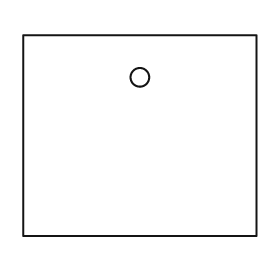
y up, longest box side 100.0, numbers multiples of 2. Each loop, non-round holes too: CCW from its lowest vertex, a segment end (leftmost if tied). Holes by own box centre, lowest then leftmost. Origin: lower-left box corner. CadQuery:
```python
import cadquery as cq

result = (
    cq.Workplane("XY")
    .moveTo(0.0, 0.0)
    .lineTo(100.0, 0.0)
    .lineTo(100.0, 86.0)
    .lineTo(0.0, 86.0)
    .close()
    .moveTo(50.0, 68.0)
    .circle(4.0)
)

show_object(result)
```